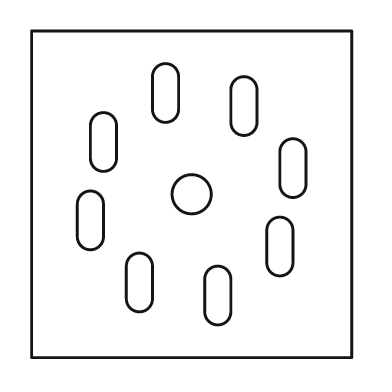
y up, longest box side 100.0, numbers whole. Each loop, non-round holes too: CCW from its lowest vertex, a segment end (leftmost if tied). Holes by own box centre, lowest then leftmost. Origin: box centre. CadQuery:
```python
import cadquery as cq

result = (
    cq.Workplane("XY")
    .moveTo(-49.0, -50.0)
    .lineTo(49.0, -50.0)
    .lineTo(49.0, 50.0)
    .lineTo(-49.0, 50.0)
    .close()
    .moveTo(4.0, -36.0)
    .threePointArc((8.0, -40.0), (12.0, -36.0))
    .lineTo(12.0, -26.0)
    .threePointArc((8.0, -22.0), (4.0, -26.0))
    .close()
    .moveTo(-20.0, -32.0)
    .threePointArc((-16.0, -36.0), (-12.0, -32.0))
    .lineTo(-12.0, -22.0)
    .threePointArc((-16.0, -18.0), (-20.0, -22.0))
    .close()
    .moveTo(23.0, -21.0)
    .threePointArc((27.0, -25.0), (31.0, -21.0))
    .lineTo(31.0, -11.0)
    .threePointArc((27.0, -7.0), (23.0, -11.0))
    .close()
    .moveTo(-35.0, -13.0)
    .threePointArc((-31.0, -17.0), (-27.0, -13.0))
    .lineTo(-27.0, -3.0)
    .threePointArc((-31.0, 1.0), (-35.0, -3.0))
    .close()
    .moveTo(0.0, 0.0)
    .circle(6.0)
    .moveTo(27.0, 3.0)
    .threePointArc((31.0, -1.0), (35.0, 3.0))
    .lineTo(35.0, 13.0)
    .threePointArc((31.0, 17.0), (27.0, 13.0))
    .close()
    .moveTo(-31.0, 11.0)
    .threePointArc((-27.0, 7.0), (-23.0, 11.0))
    .lineTo(-23.0, 21.0)
    .threePointArc((-27.0, 25.0), (-31.0, 21.0))
    .close()
    .moveTo(12.0, 22.0)
    .threePointArc((16.0, 18.0), (20.0, 22.0))
    .lineTo(20.0, 32.0)
    .threePointArc((16.0, 36.0), (12.0, 32.0))
    .close()
    .moveTo(-12.0, 26.0)
    .threePointArc((-8.0, 22.0), (-4.0, 26.0))
    .lineTo(-4.0, 36.0)
    .threePointArc((-8.0, 40.0), (-12.0, 36.0))
    .close()
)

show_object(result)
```